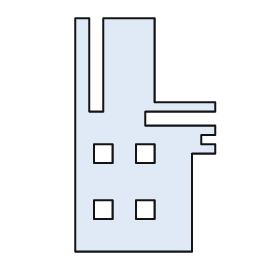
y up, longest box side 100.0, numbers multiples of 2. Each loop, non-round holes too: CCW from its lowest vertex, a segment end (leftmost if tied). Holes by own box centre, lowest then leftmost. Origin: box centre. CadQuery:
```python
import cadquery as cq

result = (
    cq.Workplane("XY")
    .moveTo(-30.0, -50.0)
    .lineTo(20.0, -50.0)
    .lineTo(20.0, -8.0)
    .lineTo(30.0, -8.0)
    .lineTo(30.0, -4.0)
    .lineTo(24.0, -4.0)
    .lineTo(24.0, 0.0)
    .lineTo(30.0, 0.0)
    .lineTo(30.0, 4.0)
    .lineTo(0.0, 4.0)
    .lineTo(0.0, 10.0)
    .lineTo(30.0, 10.0)
    .lineTo(30.0, 14.0)
    .lineTo(4.0, 14.0)
    .lineTo(4.0, 50.0)
    .lineTo(-18.0, 50.0)
    .lineTo(-18.0, 10.0)
    .lineTo(-24.0, 10.0)
    .lineTo(-24.0, 50.0)
    .lineTo(-30.0, 50.0)
    .close()
    .moveTo(-22.0, -36.0)
    .lineTo(-14.0, -36.0)
    .lineTo(-14.0, -28.0)
    .lineTo(-22.0, -28.0)
    .close()
    .moveTo(-4.0, -36.0)
    .lineTo(4.0, -36.0)
    .lineTo(4.0, -28.0)
    .lineTo(-4.0, -28.0)
    .close()
    .moveTo(-22.0, -12.0)
    .lineTo(-14.0, -12.0)
    .lineTo(-14.0, -4.0)
    .lineTo(-22.0, -4.0)
    .close()
    .moveTo(-4.0, -12.0)
    .lineTo(4.0, -12.0)
    .lineTo(4.0, -4.0)
    .lineTo(-4.0, -4.0)
    .close()
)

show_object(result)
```